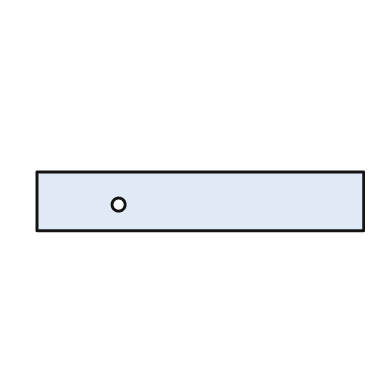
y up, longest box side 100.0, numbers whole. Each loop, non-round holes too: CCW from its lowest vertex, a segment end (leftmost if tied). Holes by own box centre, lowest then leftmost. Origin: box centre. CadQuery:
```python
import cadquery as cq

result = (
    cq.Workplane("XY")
    .moveTo(-50.0, -9.0)
    .lineTo(50.0, -9.0)
    .lineTo(50.0, 9.0)
    .lineTo(-50.0, 9.0)
    .close()
    .moveTo(-25.0, -1.0)
    .circle(2.0)
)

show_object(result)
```